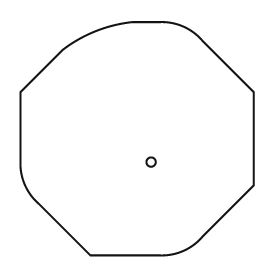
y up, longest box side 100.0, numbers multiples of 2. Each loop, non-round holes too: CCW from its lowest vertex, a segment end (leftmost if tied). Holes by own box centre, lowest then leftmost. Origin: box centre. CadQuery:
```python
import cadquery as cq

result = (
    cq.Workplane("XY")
    .moveTo(-20.0, -50.0)
    .lineTo(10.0, -50.0)
    .threePointArc((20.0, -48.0), (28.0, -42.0))
    .lineTo(50.0, -20.0)
    .lineTo(50.0, 20.0)
    .lineTo(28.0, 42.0)
    .threePointArc((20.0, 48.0), (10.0, 50.0))
    .lineTo(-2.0, 50.0)
    .threePointArc((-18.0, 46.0), (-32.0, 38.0))
    .lineTo(-50.0, 20.0)
    .lineTo(-50.0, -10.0)
    .threePointArc((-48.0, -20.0), (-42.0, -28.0))
    .close()
    .moveTo(6.0, -10.0)
    .circle(2.0)
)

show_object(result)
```